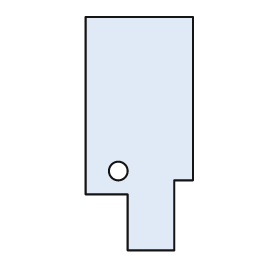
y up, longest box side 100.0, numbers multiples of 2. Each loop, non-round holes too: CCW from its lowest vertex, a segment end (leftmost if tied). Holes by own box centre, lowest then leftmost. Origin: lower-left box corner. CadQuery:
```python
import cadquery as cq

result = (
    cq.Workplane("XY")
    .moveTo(18.0, 0.0)
    .lineTo(38.0, 0.0)
    .lineTo(38.0, 30.0)
    .lineTo(46.0, 30.0)
    .lineTo(46.0, 100.0)
    .lineTo(0.0, 100.0)
    .lineTo(0.0, 24.0)
    .lineTo(18.0, 24.0)
    .close()
    .moveTo(14.0, 34.0)
    .circle(4.0)
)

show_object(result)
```